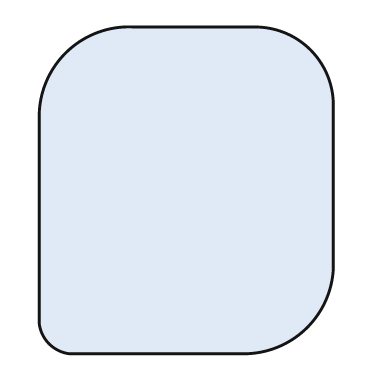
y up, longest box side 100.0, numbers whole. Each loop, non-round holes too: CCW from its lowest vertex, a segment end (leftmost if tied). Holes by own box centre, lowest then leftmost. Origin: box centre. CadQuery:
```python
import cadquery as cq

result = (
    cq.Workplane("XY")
    .moveTo(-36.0, -50.0)
    .lineTo(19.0, -50.0)
    .threePointArc((37.0, -42.0), (45.0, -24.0))
    .lineTo(45.0, 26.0)
    .threePointArc((38.0, 43.0), (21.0, 50.0))
    .lineTo(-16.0, 50.0)
    .threePointArc((-37.0, 42.0), (-45.0, 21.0))
    .lineTo(-45.0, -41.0)
    .threePointArc((-42.0, -47.0), (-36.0, -50.0))
    .close()
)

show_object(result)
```